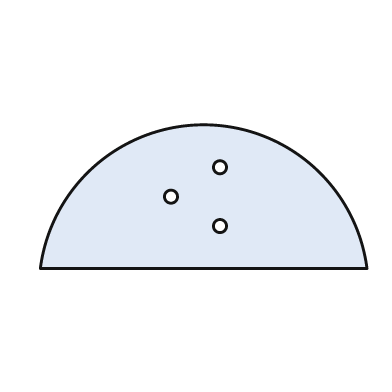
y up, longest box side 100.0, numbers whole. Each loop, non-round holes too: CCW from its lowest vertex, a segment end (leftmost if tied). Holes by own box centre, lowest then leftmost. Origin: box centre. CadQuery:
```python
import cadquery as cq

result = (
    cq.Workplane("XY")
    .moveTo(-50.0, -22.0)
    .lineTo(50.0, -22.0)
    .threePointArc((0.0, 22.0), (-50.0, -22.0))
    .close()
    .moveTo(5.0, -9.0)
    .circle(2.0)
    .moveTo(-10.0, 0.0)
    .circle(2.0)
    .moveTo(5.0, 9.0)
    .circle(2.0)
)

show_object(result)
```